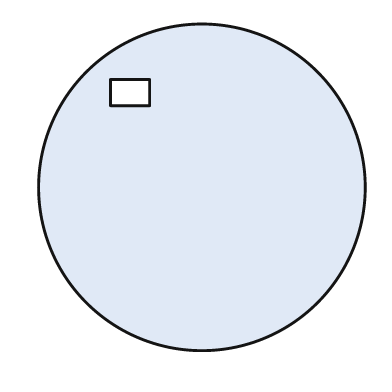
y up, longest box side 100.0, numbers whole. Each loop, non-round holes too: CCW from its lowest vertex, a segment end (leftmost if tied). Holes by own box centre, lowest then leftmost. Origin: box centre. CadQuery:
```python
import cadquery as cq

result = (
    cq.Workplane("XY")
    .moveTo(0.0, 0.0)
    .circle(50.0)
    .moveTo(-28.0, 25.0)
    .lineTo(-16.0, 25.0)
    .lineTo(-16.0, 33.0)
    .lineTo(-28.0, 33.0)
    .close()
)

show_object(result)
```